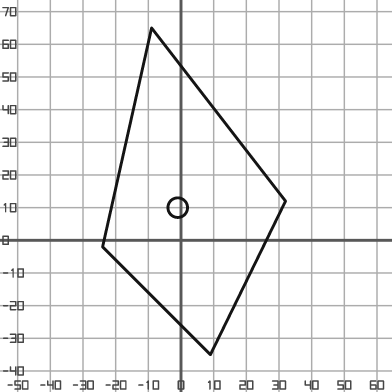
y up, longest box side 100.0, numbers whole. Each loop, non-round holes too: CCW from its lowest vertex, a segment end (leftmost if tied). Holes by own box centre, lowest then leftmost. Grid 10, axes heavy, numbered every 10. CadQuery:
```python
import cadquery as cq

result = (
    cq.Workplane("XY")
    .moveTo(9.0, -35.0)
    .lineTo(32.0, 12.0)
    .lineTo(-9.0, 65.0)
    .lineTo(-24.0, -2.0)
    .close()
    .moveTo(-1.0, 10.0)
    .circle(3.0)
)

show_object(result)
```